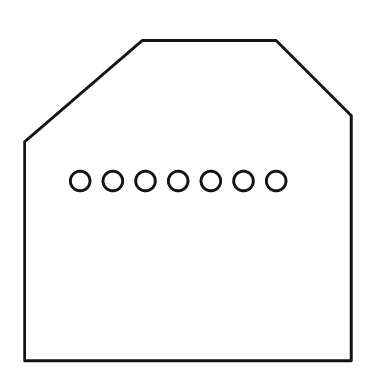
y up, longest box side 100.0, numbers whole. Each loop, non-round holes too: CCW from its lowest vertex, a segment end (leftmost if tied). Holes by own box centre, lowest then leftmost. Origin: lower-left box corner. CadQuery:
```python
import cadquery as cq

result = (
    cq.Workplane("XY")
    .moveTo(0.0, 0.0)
    .lineTo(100.0, 0.0)
    .lineTo(100.0, 75.0)
    .lineTo(77.0, 98.0)
    .lineTo(36.0, 98.0)
    .lineTo(0.0, 67.0)
    .close()
    .moveTo(17.0, 55.0)
    .circle(3.0)
    .moveTo(27.0, 55.0)
    .circle(3.0)
    .moveTo(37.0, 55.0)
    .circle(3.0)
    .moveTo(47.0, 55.0)
    .circle(3.0)
    .moveTo(57.0, 55.0)
    .circle(3.0)
    .moveTo(67.0, 55.0)
    .circle(3.0)
    .moveTo(77.0, 55.0)
    .circle(3.0)
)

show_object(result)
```